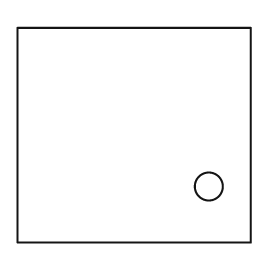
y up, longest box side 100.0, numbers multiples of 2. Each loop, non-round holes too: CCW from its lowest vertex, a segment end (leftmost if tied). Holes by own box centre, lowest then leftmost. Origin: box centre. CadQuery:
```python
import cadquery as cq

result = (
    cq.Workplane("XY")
    .moveTo(-50.0, -46.0)
    .lineTo(50.0, -46.0)
    .lineTo(50.0, 46.0)
    .lineTo(-50.0, 46.0)
    .close()
    .moveTo(32.0, -22.0)
    .circle(6.0)
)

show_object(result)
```